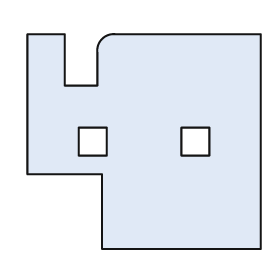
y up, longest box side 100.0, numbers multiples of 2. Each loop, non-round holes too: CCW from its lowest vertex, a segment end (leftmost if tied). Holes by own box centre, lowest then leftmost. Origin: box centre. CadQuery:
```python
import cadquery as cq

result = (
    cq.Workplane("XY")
    .moveTo(-18.0, -46.0)
    .lineTo(50.0, -46.0)
    .lineTo(50.0, 46.0)
    .lineTo(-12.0, 46.0)
    .threePointArc((-18.0, 44.0), (-20.0, 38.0))
    .lineTo(-20.0, 24.0)
    .lineTo(-34.0, 24.0)
    .lineTo(-34.0, 46.0)
    .lineTo(-50.0, 46.0)
    .lineTo(-50.0, -14.0)
    .lineTo(-18.0, -14.0)
    .close()
    .moveTo(-28.0, -6.0)
    .lineTo(-16.0, -6.0)
    .lineTo(-16.0, 6.0)
    .lineTo(-28.0, 6.0)
    .close()
    .moveTo(16.0, -6.0)
    .lineTo(28.0, -6.0)
    .lineTo(28.0, 6.0)
    .lineTo(16.0, 6.0)
    .close()
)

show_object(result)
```